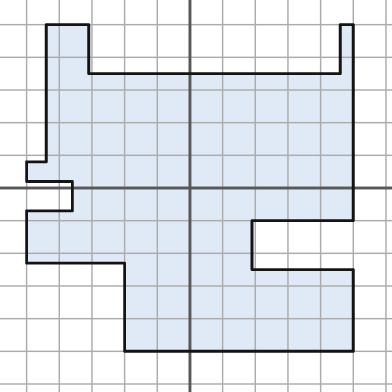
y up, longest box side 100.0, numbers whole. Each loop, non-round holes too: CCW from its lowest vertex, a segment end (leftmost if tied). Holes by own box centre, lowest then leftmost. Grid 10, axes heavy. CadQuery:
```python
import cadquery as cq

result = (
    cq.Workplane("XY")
    .moveTo(-20.0, -50.0)
    .lineTo(50.0, -50.0)
    .lineTo(50.0, -25.0)
    .lineTo(19.0, -25.0)
    .lineTo(19.0, -10.0)
    .lineTo(50.0, -10.0)
    .lineTo(50.0, 50.0)
    .lineTo(46.0, 50.0)
    .lineTo(46.0, 35.0)
    .lineTo(-31.0, 35.0)
    .lineTo(-31.0, 50.0)
    .lineTo(-44.0, 50.0)
    .lineTo(-44.0, 8.0)
    .lineTo(-50.0, 8.0)
    .lineTo(-50.0, 2.0)
    .lineTo(-36.0, 2.0)
    .lineTo(-36.0, -7.0)
    .lineTo(-50.0, -7.0)
    .lineTo(-50.0, -23.0)
    .lineTo(-20.0, -23.0)
    .close()
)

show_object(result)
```